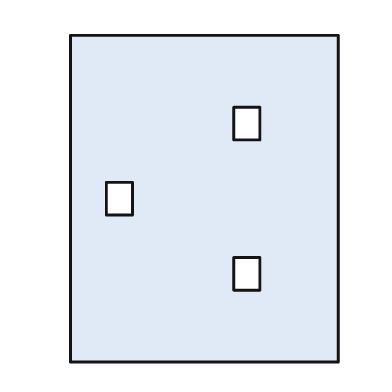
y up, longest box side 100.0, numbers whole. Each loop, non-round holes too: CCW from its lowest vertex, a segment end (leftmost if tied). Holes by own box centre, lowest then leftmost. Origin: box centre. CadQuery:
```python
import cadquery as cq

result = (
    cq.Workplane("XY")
    .moveTo(-41.0, -50.0)
    .lineTo(41.0, -50.0)
    .lineTo(41.0, 50.0)
    .lineTo(-41.0, 50.0)
    .close()
    .moveTo(9.0, -28.0)
    .lineTo(17.0, -28.0)
    .lineTo(17.0, -18.0)
    .lineTo(9.0, -18.0)
    .close()
    .moveTo(-30.0, -5.0)
    .lineTo(-22.0, -5.0)
    .lineTo(-22.0, 5.0)
    .lineTo(-30.0, 5.0)
    .close()
    .moveTo(9.0, 18.0)
    .lineTo(17.0, 18.0)
    .lineTo(17.0, 28.0)
    .lineTo(9.0, 28.0)
    .close()
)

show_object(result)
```